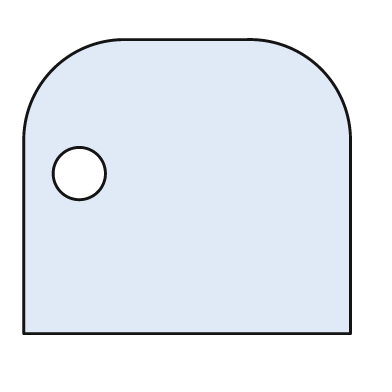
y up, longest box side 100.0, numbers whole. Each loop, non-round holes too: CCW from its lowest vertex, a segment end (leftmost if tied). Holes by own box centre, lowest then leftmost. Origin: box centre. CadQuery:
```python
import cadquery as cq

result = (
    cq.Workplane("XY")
    .moveTo(-50.0, -45.0)
    .lineTo(50.0, -45.0)
    .lineTo(50.0, 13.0)
    .threePointArc((41.0, 36.0), (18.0, 45.0))
    .lineTo(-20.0, 45.0)
    .threePointArc((-41.0, 36.0), (-50.0, 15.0))
    .close()
    .moveTo(-33.0, 4.0)
    .circle(8.0)
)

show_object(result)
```